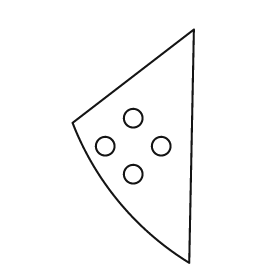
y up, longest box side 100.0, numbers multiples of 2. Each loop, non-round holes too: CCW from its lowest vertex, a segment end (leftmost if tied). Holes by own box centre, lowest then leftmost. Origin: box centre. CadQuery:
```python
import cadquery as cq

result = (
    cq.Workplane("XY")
    .moveTo(24.0, -50.0)
    .lineTo(26.0, 50.0)
    .lineTo(-26.0, 10.0)
    .threePointArc((-6.0, -24.0), (24.0, -50.0))
    .close()
    .moveTo(0.0, -12.0)
    .circle(4.0)
    .moveTo(-12.0, 0.0)
    .circle(4.0)
    .moveTo(12.0, 0.0)
    .circle(4.0)
    .moveTo(0.0, 12.0)
    .circle(4.0)
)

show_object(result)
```